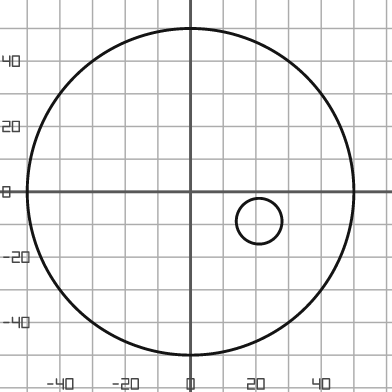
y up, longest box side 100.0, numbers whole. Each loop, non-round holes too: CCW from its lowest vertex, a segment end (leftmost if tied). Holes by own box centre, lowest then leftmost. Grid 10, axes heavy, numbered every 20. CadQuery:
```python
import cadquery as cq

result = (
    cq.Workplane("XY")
    .moveTo(0.0, 0.0)
    .circle(50.0)
    .moveTo(21.0, -9.0)
    .circle(7.0)
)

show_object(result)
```